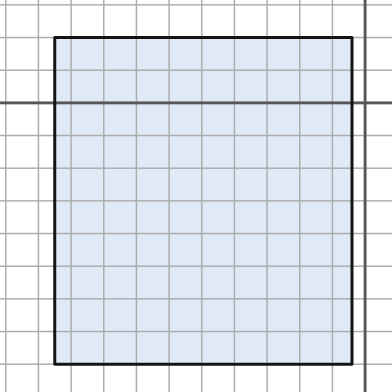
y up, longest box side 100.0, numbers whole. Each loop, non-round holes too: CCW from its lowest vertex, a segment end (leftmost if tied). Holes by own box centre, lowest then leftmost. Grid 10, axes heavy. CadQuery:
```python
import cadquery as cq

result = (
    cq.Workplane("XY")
    .moveTo(-95.0, -80.0)
    .lineTo(-4.0, -80.0)
    .lineTo(-4.0, 20.0)
    .lineTo(-95.0, 20.0)
    .close()
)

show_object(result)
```